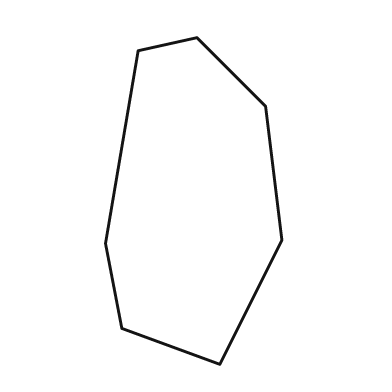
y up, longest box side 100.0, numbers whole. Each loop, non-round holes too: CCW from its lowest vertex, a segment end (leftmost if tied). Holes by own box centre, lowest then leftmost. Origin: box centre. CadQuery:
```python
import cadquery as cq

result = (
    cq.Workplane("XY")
    .moveTo(8.0, -50.0)
    .lineTo(27.0, -12.0)
    .lineTo(22.0, 29.0)
    .lineTo(1.0, 50.0)
    .lineTo(-17.0, 46.0)
    .lineTo(-27.0, -13.0)
    .lineTo(-22.0, -39.0)
    .close()
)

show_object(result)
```